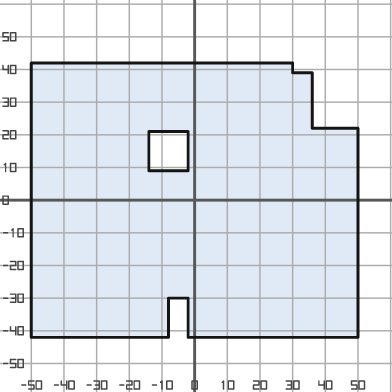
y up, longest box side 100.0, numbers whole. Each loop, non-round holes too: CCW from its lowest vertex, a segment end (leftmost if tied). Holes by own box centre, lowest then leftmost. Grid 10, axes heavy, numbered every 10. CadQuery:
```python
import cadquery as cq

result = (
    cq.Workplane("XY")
    .moveTo(-50.0, -42.0)
    .lineTo(-8.0, -42.0)
    .lineTo(-8.0, -30.0)
    .lineTo(-2.0, -30.0)
    .lineTo(-2.0, -42.0)
    .lineTo(50.0, -42.0)
    .lineTo(50.0, 22.0)
    .lineTo(36.0, 22.0)
    .lineTo(36.0, 39.0)
    .lineTo(30.0, 39.0)
    .lineTo(30.0, 42.0)
    .lineTo(-50.0, 42.0)
    .close()
    .moveTo(-14.0, 9.0)
    .lineTo(-2.0, 9.0)
    .lineTo(-2.0, 21.0)
    .lineTo(-14.0, 21.0)
    .close()
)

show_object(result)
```